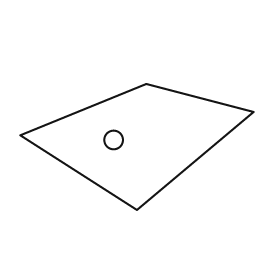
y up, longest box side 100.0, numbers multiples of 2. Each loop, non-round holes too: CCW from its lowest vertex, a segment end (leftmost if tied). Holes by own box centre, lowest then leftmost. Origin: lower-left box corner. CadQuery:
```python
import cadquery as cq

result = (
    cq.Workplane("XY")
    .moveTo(50.0, 0.0)
    .lineTo(100.0, 42.0)
    .lineTo(54.0, 54.0)
    .lineTo(0.0, 32.0)
    .close()
    .moveTo(40.0, 30.0)
    .circle(4.0)
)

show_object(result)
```